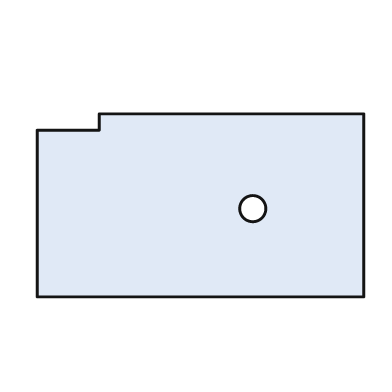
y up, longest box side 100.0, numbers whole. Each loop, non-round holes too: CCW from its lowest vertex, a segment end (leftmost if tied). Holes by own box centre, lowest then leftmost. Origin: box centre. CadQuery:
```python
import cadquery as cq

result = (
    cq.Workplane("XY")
    .moveTo(-50.0, -28.0)
    .lineTo(50.0, -28.0)
    .lineTo(50.0, 28.0)
    .lineTo(-31.0, 28.0)
    .lineTo(-31.0, 23.0)
    .lineTo(-50.0, 23.0)
    .close()
    .moveTo(16.0, -1.0)
    .circle(4.0)
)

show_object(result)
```